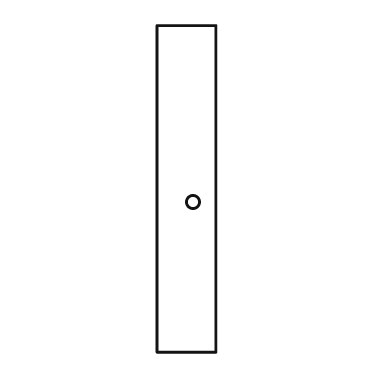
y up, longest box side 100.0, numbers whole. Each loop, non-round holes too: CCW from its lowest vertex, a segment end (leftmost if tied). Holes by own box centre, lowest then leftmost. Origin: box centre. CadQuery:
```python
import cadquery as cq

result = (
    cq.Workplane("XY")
    .moveTo(-9.0, -50.0)
    .lineTo(9.0, -50.0)
    .lineTo(9.0, 50.0)
    .lineTo(-9.0, 50.0)
    .close()
    .moveTo(2.0, -4.0)
    .circle(2.0)
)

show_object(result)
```